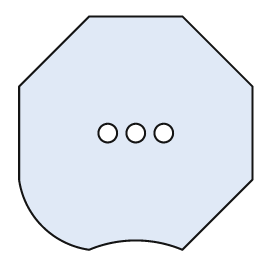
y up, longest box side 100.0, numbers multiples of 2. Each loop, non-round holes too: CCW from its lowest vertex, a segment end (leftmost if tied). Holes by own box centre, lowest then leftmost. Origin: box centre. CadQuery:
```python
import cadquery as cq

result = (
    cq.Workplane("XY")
    .moveTo(-20.0, -50.0)
    .threePointArc((0.0, -46.0), (20.0, -50.0))
    .lineTo(50.0, -20.0)
    .lineTo(50.0, 20.0)
    .lineTo(20.0, 50.0)
    .lineTo(-20.0, 50.0)
    .lineTo(-50.0, 20.0)
    .lineTo(-50.0, -20.0)
    .threePointArc((-40.0, -40.0), (-20.0, -50.0))
    .close()
    .moveTo(-12.0, 0.0)
    .circle(4.0)
    .moveTo(0.0, 0.0)
    .circle(4.0)
    .moveTo(12.0, 0.0)
    .circle(4.0)
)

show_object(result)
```